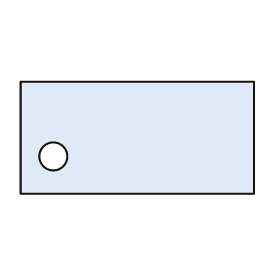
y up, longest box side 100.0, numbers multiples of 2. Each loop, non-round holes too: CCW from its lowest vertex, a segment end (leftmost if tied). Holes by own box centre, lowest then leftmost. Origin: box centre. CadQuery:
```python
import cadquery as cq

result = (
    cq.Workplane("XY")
    .moveTo(-50.0, -24.0)
    .lineTo(50.0, -24.0)
    .lineTo(50.0, 24.0)
    .lineTo(-50.0, 24.0)
    .close()
    .moveTo(-36.0, -8.0)
    .circle(6.0)
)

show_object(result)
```